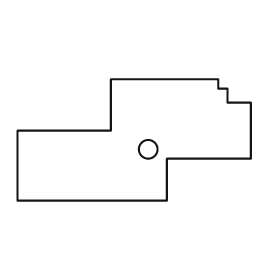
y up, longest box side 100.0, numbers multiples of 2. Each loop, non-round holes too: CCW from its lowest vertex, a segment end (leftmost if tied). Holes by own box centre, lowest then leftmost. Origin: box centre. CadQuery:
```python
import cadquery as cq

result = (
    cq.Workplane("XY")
    .moveTo(-50.0, -26.0)
    .lineTo(14.0, -26.0)
    .lineTo(14.0, -8.0)
    .lineTo(50.0, -8.0)
    .lineTo(50.0, 16.0)
    .lineTo(40.0, 16.0)
    .lineTo(40.0, 22.0)
    .lineTo(36.0, 22.0)
    .lineTo(36.0, 26.0)
    .lineTo(-10.0, 26.0)
    .lineTo(-10.0, 4.0)
    .lineTo(-50.0, 4.0)
    .close()
    .moveTo(6.0, -4.0)
    .circle(4.0)
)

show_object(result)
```